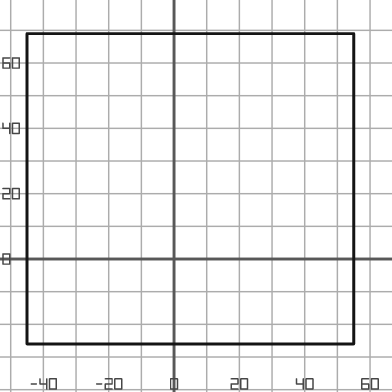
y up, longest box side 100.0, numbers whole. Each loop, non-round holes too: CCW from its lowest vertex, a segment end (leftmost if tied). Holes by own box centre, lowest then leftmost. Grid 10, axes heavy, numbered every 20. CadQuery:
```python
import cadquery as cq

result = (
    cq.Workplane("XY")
    .moveTo(-45.0, -26.0)
    .lineTo(55.0, -26.0)
    .lineTo(55.0, 69.0)
    .lineTo(-45.0, 69.0)
    .close()
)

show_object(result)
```